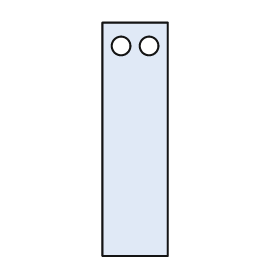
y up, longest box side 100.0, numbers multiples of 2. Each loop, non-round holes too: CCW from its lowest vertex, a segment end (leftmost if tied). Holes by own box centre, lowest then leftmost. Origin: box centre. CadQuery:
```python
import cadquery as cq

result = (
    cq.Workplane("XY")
    .moveTo(-14.0, -50.0)
    .lineTo(14.0, -50.0)
    .lineTo(14.0, 50.0)
    .lineTo(-14.0, 50.0)
    .close()
    .moveTo(-6.0, 40.0)
    .circle(4.0)
    .moveTo(6.0, 40.0)
    .circle(4.0)
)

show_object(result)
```